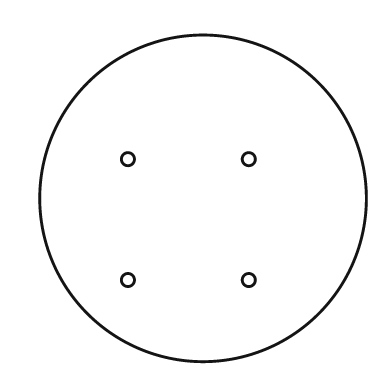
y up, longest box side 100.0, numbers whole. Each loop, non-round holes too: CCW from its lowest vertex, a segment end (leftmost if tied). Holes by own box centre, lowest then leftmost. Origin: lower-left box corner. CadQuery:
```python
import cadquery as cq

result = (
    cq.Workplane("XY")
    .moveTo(50.0, 50.0)
    .circle(50.0)
    .moveTo(27.0, 25.0)
    .circle(2.0)
    .moveTo(64.0, 25.0)
    .circle(2.0)
    .moveTo(27.0, 62.0)
    .circle(2.0)
    .moveTo(64.0, 62.0)
    .circle(2.0)
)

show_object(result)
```